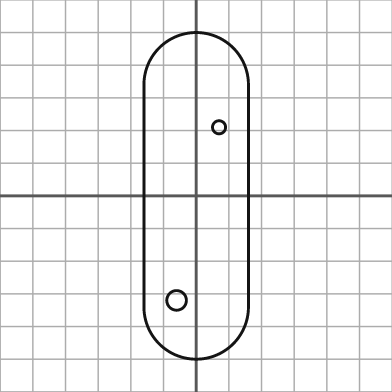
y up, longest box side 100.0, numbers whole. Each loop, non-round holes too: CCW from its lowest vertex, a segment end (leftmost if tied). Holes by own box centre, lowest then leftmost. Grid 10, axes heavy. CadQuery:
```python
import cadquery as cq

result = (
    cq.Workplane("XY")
    .moveTo(-16.0, -34.0)
    .threePointArc((0.0, -50.0), (16.0, -34.0))
    .lineTo(16.0, 34.0)
    .threePointArc((0.0, 50.0), (-16.0, 34.0))
    .close()
    .moveTo(-6.0, -32.0)
    .circle(3.0)
    .moveTo(7.0, 21.0)
    .circle(2.0)
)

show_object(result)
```